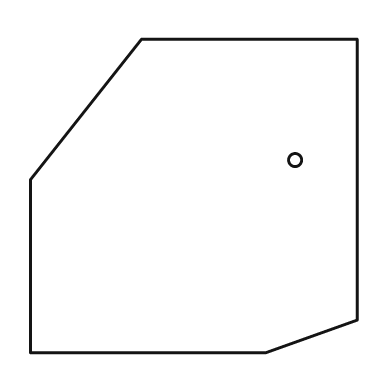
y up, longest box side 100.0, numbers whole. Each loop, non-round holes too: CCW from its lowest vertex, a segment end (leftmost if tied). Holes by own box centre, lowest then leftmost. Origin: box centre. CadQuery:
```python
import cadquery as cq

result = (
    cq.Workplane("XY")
    .moveTo(-50.0, -48.0)
    .lineTo(22.0, -48.0)
    .lineTo(50.0, -38.0)
    .lineTo(50.0, 48.0)
    .lineTo(-16.0, 48.0)
    .lineTo(-50.0, 5.0)
    .close()
    .moveTo(31.0, 11.0)
    .circle(2.0)
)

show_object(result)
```